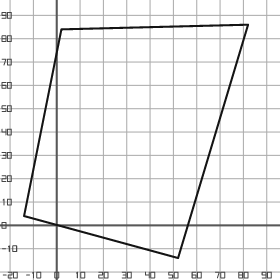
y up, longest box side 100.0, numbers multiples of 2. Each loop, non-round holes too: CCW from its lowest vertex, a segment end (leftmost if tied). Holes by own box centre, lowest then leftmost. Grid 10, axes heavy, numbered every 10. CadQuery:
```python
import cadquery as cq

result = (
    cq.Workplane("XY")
    .moveTo(52.0, -14.0)
    .lineTo(82.0, 86.0)
    .lineTo(2.0, 84.0)
    .lineTo(-14.0, 4.0)
    .close()
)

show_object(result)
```